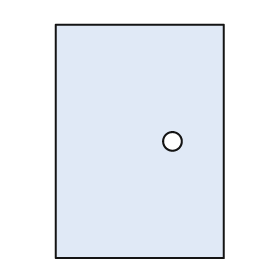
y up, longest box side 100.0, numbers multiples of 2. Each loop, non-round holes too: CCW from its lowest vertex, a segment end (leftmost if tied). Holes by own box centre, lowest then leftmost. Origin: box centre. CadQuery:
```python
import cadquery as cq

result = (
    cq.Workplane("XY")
    .moveTo(-36.0, -50.0)
    .lineTo(36.0, -50.0)
    .lineTo(36.0, 50.0)
    .lineTo(-36.0, 50.0)
    .close()
    .moveTo(14.0, 0.0)
    .circle(4.0)
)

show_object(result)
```